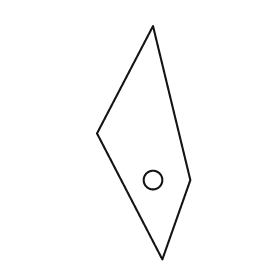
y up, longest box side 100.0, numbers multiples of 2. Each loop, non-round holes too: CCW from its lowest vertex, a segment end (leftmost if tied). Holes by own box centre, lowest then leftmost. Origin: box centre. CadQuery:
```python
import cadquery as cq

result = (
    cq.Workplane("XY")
    .moveTo(8.0, -50.0)
    .lineTo(20.0, -16.0)
    .lineTo(4.0, 50.0)
    .lineTo(-20.0, 4.0)
    .close()
    .moveTo(4.0, -16.0)
    .circle(4.0)
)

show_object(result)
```